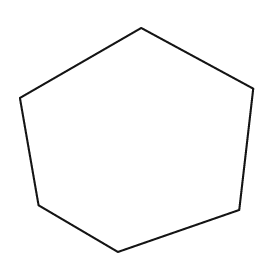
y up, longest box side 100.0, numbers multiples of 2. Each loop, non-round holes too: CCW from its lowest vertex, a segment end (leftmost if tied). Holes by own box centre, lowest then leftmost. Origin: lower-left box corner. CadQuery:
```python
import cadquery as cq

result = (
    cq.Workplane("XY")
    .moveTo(42.0, 0.0)
    .lineTo(94.0, 18.0)
    .lineTo(100.0, 70.0)
    .lineTo(52.0, 96.0)
    .lineTo(0.0, 66.0)
    .lineTo(8.0, 20.0)
    .close()
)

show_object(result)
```